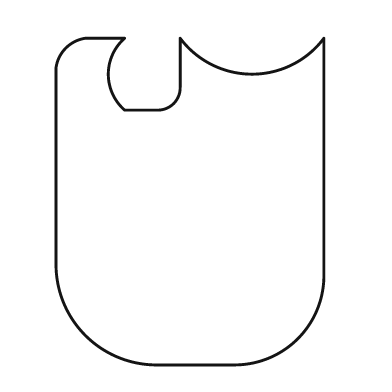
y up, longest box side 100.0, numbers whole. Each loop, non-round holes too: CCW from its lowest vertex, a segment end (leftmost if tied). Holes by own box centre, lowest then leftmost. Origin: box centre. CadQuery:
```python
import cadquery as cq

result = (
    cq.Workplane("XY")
    .moveTo(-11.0, -50.0)
    .lineTo(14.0, -50.0)
    .threePointArc((33.0, -42.0), (41.0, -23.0))
    .lineTo(41.0, 50.0)
    .threePointArc((19.0, 39.0), (-3.0, 50.0))
    .lineTo(-3.0, 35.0)
    .threePointArc((-5.0, 30.0), (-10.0, 28.0))
    .lineTo(-20.0, 28.0)
    .threePointArc((-25.0, 39.0), (-20.0, 50.0))
    .lineTo(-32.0, 50.0)
    .threePointArc((-38.0, 47.0), (-41.0, 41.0))
    .lineTo(-41.0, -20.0)
    .threePointArc((-32.0, -41.0), (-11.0, -50.0))
    .close()
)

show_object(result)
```